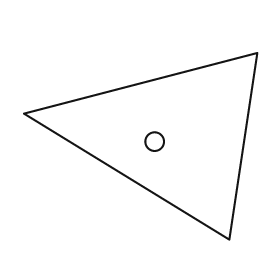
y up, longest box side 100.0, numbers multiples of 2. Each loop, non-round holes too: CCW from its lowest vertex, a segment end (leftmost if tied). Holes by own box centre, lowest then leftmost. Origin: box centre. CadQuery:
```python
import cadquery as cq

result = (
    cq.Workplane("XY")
    .moveTo(38.0, -40.0)
    .lineTo(50.0, 40.0)
    .lineTo(-50.0, 14.0)
    .close()
    .moveTo(6.0, 2.0)
    .circle(4.0)
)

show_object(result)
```